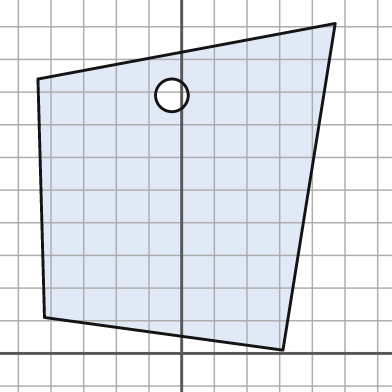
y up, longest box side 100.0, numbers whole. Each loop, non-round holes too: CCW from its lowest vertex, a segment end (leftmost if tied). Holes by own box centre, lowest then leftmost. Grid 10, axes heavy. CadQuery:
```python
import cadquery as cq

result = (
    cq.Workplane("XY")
    .moveTo(31.0, 1.0)
    .lineTo(47.0, 101.0)
    .lineTo(-44.0, 84.0)
    .lineTo(-42.0, 11.0)
    .close()
    .moveTo(-3.0, 79.0)
    .circle(5.0)
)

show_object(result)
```